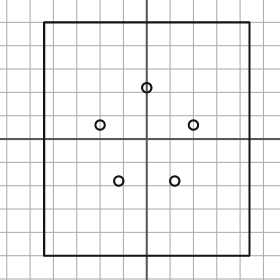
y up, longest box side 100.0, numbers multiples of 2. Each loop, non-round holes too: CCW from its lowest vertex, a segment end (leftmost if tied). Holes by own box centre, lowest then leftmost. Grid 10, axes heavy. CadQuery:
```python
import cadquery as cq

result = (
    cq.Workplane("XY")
    .moveTo(-44.0, -50.0)
    .lineTo(44.0, -50.0)
    .lineTo(44.0, 50.0)
    .lineTo(-44.0, 50.0)
    .close()
    .moveTo(-12.0, -18.0)
    .circle(2.0)
    .moveTo(12.0, -18.0)
    .circle(2.0)
    .moveTo(-20.0, 6.0)
    .circle(2.0)
    .moveTo(20.0, 6.0)
    .circle(2.0)
    .moveTo(0.0, 22.0)
    .circle(2.0)
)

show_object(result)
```